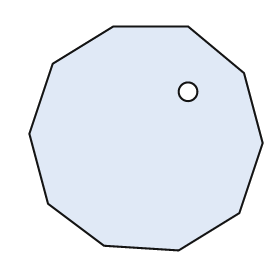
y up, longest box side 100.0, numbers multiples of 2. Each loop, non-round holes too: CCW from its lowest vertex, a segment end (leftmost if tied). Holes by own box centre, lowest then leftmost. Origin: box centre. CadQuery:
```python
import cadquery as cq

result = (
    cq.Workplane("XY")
    .moveTo(14.0, -48.0)
    .lineTo(40.0, -32.0)
    .lineTo(50.0, -2.0)
    .lineTo(42.0, 28.0)
    .lineTo(18.0, 48.0)
    .lineTo(-14.0, 48.0)
    .lineTo(-40.0, 32.0)
    .lineTo(-50.0, 2.0)
    .lineTo(-42.0, -28.0)
    .lineTo(-18.0, -46.0)
    .close()
    .moveTo(18.0, 20.0)
    .circle(4.0)
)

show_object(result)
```